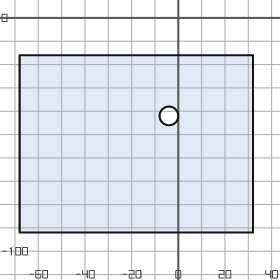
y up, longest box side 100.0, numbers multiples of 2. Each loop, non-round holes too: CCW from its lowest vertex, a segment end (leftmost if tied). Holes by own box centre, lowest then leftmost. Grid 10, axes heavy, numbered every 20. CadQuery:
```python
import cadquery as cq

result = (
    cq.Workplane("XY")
    .moveTo(-68.0, -92.0)
    .lineTo(32.0, -92.0)
    .lineTo(32.0, -16.0)
    .lineTo(-68.0, -16.0)
    .close()
    .moveTo(-4.0, -42.0)
    .circle(4.0)
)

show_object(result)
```